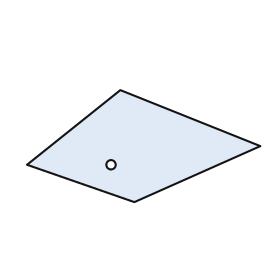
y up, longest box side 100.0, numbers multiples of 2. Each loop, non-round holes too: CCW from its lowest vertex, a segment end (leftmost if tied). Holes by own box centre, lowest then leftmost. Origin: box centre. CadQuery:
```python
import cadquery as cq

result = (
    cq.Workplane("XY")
    .moveTo(-4.0, -24.0)
    .lineTo(50.0, 0.0)
    .lineTo(-10.0, 24.0)
    .lineTo(-50.0, -8.0)
    .close()
    .moveTo(-14.0, -8.0)
    .circle(2.0)
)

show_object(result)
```